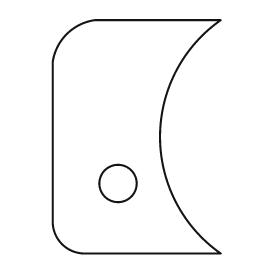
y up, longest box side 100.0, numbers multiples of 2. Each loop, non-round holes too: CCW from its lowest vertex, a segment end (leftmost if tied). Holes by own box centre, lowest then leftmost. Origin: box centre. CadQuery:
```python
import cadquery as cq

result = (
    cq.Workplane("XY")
    .moveTo(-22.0, -50.0)
    .lineTo(36.0, -50.0)
    .threePointArc((10.0, 0.0), (36.0, 50.0))
    .lineTo(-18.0, 50.0)
    .threePointArc((-30.0, 44.0), (-36.0, 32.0))
    .lineTo(-36.0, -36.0)
    .threePointArc((-32.0, -46.0), (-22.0, -50.0))
    .close()
    .moveTo(-8.0, -20.0)
    .circle(8.0)
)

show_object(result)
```